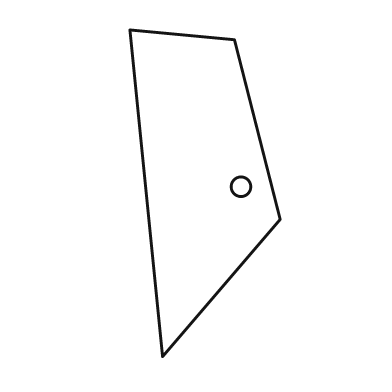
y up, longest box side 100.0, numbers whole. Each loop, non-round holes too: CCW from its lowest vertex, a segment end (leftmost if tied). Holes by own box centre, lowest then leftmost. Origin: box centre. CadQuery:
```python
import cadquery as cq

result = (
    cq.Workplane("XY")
    .moveTo(-13.0, -50.0)
    .lineTo(23.0, -8.0)
    .lineTo(9.0, 47.0)
    .lineTo(-23.0, 50.0)
    .close()
    .moveTo(11.0, 2.0)
    .circle(3.0)
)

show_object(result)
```